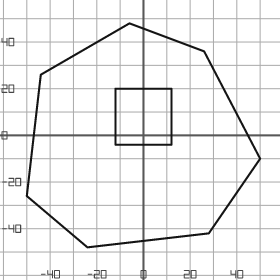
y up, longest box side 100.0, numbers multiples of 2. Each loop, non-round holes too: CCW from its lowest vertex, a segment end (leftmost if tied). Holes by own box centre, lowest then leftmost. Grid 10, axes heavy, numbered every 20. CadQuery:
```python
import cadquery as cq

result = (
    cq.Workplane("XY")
    .moveTo(-24.0, -48.0)
    .lineTo(28.0, -42.0)
    .lineTo(50.0, -10.0)
    .lineTo(26.0, 36.0)
    .lineTo(-6.0, 48.0)
    .lineTo(-44.0, 26.0)
    .lineTo(-50.0, -26.0)
    .close()
    .moveTo(-12.0, -4.0)
    .lineTo(12.0, -4.0)
    .lineTo(12.0, 20.0)
    .lineTo(-12.0, 20.0)
    .close()
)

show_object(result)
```